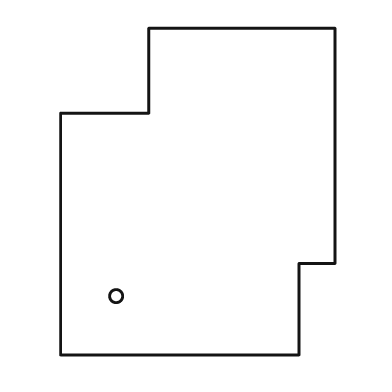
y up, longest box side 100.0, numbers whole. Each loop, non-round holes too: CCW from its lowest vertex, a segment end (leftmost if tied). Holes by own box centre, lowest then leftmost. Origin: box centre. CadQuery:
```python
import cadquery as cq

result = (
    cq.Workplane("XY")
    .moveTo(-42.0, -50.0)
    .lineTo(31.0, -50.0)
    .lineTo(31.0, -22.0)
    .lineTo(42.0, -22.0)
    .lineTo(42.0, 50.0)
    .lineTo(-15.0, 50.0)
    .lineTo(-15.0, 24.0)
    .lineTo(-42.0, 24.0)
    .close()
    .moveTo(-25.0, -32.0)
    .circle(2.0)
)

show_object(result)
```